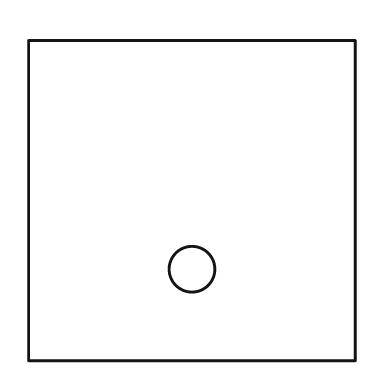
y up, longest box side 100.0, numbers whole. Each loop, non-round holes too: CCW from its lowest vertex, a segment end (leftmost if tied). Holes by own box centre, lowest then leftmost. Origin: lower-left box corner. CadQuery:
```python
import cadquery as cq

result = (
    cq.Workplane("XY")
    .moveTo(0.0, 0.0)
    .lineTo(100.0, 0.0)
    .lineTo(100.0, 98.0)
    .lineTo(0.0, 98.0)
    .close()
    .moveTo(50.0, 28.0)
    .circle(7.0)
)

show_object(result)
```